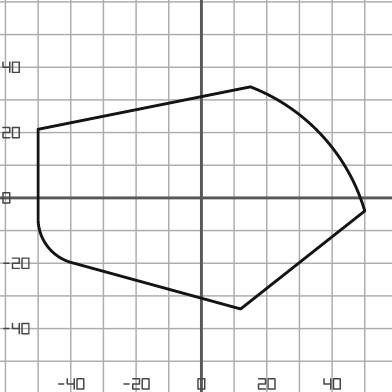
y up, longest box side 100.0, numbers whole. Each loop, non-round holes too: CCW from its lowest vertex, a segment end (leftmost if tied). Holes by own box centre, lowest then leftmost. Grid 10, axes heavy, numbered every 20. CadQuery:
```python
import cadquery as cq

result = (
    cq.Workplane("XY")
    .moveTo(12.0, -34.0)
    .lineTo(50.0, -4.0)
    .threePointArc((37.0, 19.0), (15.0, 34.0))
    .lineTo(-50.0, 21.0)
    .lineTo(-50.0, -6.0)
    .threePointArc((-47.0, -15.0), (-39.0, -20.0))
    .close()
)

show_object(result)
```